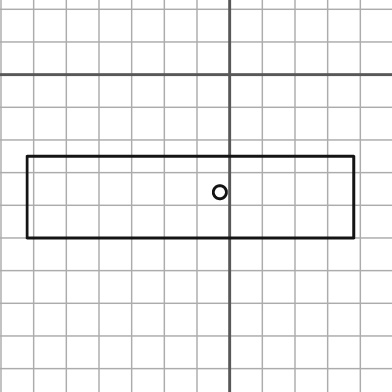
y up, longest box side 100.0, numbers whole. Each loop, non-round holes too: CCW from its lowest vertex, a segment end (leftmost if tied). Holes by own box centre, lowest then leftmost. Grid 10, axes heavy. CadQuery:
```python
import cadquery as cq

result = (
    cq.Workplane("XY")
    .moveTo(-62.0, -50.0)
    .lineTo(38.0, -50.0)
    .lineTo(38.0, -25.0)
    .lineTo(-62.0, -25.0)
    .close()
    .moveTo(-3.0, -36.0)
    .circle(2.0)
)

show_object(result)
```